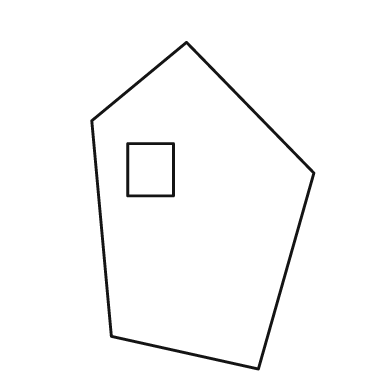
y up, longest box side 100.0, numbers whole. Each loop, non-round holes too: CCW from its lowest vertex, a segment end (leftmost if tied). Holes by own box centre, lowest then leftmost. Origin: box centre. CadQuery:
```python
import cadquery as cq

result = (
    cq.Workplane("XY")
    .moveTo(17.0, -50.0)
    .lineTo(34.0, 10.0)
    .lineTo(-5.0, 50.0)
    .lineTo(-34.0, 26.0)
    .lineTo(-28.0, -40.0)
    .close()
    .moveTo(-23.0, 3.0)
    .lineTo(-9.0, 3.0)
    .lineTo(-9.0, 19.0)
    .lineTo(-23.0, 19.0)
    .close()
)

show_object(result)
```